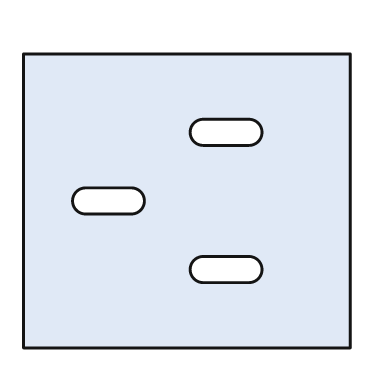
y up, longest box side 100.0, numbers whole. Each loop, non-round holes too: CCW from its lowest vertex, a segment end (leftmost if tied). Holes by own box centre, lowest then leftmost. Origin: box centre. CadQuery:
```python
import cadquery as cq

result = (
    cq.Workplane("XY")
    .moveTo(-50.0, -45.0)
    .lineTo(50.0, -45.0)
    .lineTo(50.0, 45.0)
    .lineTo(-50.0, 45.0)
    .close()
    .moveTo(5.0, -25.0)
    .lineTo(19.0, -25.0)
    .threePointArc((23.0, -21.0), (19.0, -17.0))
    .lineTo(5.0, -17.0)
    .threePointArc((1.0, -21.0), (5.0, -25.0))
    .close()
    .moveTo(-31.0, -4.0)
    .lineTo(-17.0, -4.0)
    .threePointArc((-13.0, 0.0), (-17.0, 4.0))
    .lineTo(-31.0, 4.0)
    .threePointArc((-35.0, 0.0), (-31.0, -4.0))
    .close()
    .moveTo(5.0, 17.0)
    .lineTo(19.0, 17.0)
    .threePointArc((23.0, 21.0), (19.0, 25.0))
    .lineTo(5.0, 25.0)
    .threePointArc((1.0, 21.0), (5.0, 17.0))
    .close()
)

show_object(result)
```